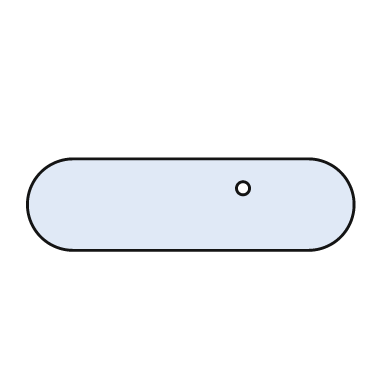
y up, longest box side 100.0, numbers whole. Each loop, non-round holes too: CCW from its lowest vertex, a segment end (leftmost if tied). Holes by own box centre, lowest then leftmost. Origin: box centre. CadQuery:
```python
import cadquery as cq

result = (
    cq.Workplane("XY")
    .moveTo(-36.0, -14.0)
    .lineTo(36.0, -14.0)
    .threePointArc((50.0, 0.0), (36.0, 14.0))
    .lineTo(-36.0, 14.0)
    .threePointArc((-50.0, 0.0), (-36.0, -14.0))
    .close()
    .moveTo(16.0, 5.0)
    .circle(2.0)
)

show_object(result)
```